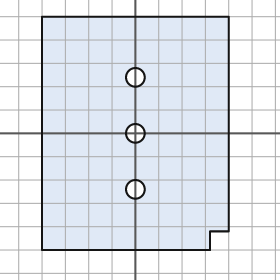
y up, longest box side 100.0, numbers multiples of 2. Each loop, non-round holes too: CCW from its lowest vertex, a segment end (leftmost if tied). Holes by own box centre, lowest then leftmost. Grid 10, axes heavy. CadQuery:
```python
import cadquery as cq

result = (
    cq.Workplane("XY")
    .moveTo(-40.0, -50.0)
    .lineTo(32.0, -50.0)
    .lineTo(32.0, -42.0)
    .lineTo(40.0, -42.0)
    .lineTo(40.0, 50.0)
    .lineTo(-40.0, 50.0)
    .close()
    .moveTo(0.0, -24.0)
    .circle(4.0)
    .moveTo(0.0, 0.0)
    .circle(4.0)
    .moveTo(0.0, 24.0)
    .circle(4.0)
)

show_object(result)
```